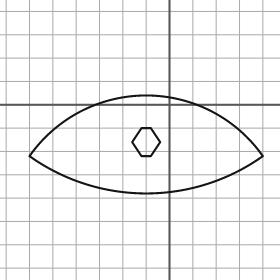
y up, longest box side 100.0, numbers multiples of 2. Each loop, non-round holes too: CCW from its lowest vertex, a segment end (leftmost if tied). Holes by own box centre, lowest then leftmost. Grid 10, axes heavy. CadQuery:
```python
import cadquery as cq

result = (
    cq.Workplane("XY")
    .moveTo(-60.0, -22.0)
    .threePointArc((-10.0, -38.0), (40.0, -22.0))
    .threePointArc((-10.0, 4.0), (-60.0, -22.0))
    .close()
    .moveTo(-12.0, -22.0)
    .lineTo(-8.0, -22.0)
    .lineTo(-4.0, -16.0)
    .lineTo(-8.0, -10.0)
    .lineTo(-12.0, -10.0)
    .lineTo(-16.0, -16.0)
    .close()
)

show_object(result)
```